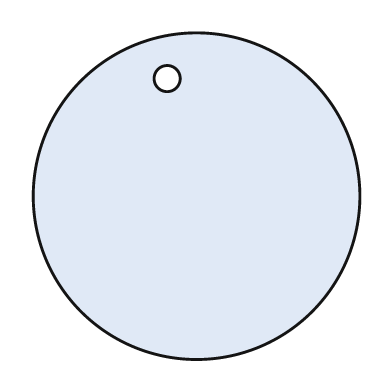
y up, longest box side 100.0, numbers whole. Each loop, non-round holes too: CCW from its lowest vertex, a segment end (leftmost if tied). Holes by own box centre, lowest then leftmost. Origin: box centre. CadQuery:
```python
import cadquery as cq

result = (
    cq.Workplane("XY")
    .moveTo(0.0, 0.0)
    .circle(50.0)
    .moveTo(-9.0, 36.0)
    .circle(4.0)
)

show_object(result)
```